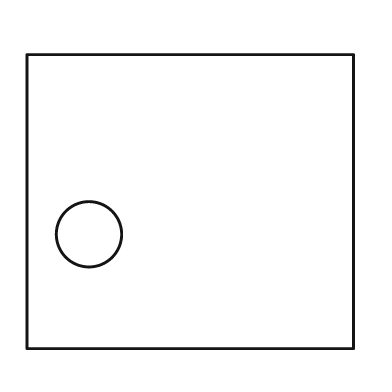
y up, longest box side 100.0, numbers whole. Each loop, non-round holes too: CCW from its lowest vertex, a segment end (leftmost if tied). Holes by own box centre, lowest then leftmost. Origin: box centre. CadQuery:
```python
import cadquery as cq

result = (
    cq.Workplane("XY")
    .moveTo(-50.0, -45.0)
    .lineTo(50.0, -45.0)
    .lineTo(50.0, 45.0)
    .lineTo(-50.0, 45.0)
    .close()
    .moveTo(-31.0, -10.0)
    .circle(10.0)
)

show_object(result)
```